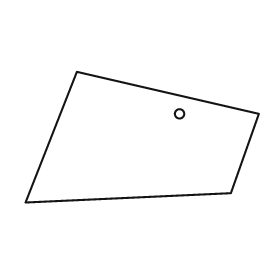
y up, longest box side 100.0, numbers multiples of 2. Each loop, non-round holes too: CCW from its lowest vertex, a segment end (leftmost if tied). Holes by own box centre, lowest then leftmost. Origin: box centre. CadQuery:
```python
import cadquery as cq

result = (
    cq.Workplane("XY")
    .moveTo(-50.0, -28.0)
    .lineTo(38.0, -24.0)
    .lineTo(50.0, 10.0)
    .lineTo(-28.0, 28.0)
    .close()
    .moveTo(16.0, 10.0)
    .circle(2.0)
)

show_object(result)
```